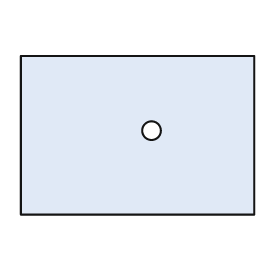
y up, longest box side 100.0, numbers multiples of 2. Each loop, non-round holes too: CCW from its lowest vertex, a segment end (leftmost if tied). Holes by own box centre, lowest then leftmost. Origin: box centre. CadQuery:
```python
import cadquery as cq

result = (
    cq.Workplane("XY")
    .moveTo(-50.0, -34.0)
    .lineTo(50.0, -34.0)
    .lineTo(50.0, 34.0)
    .lineTo(-50.0, 34.0)
    .close()
    .moveTo(6.0, 2.0)
    .circle(4.0)
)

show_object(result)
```